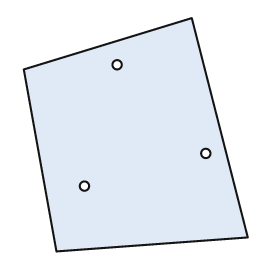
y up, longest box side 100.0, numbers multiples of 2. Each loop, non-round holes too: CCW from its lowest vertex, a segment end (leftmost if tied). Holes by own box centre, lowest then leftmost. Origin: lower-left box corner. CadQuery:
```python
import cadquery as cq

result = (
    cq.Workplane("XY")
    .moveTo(14.0, 0.0)
    .lineTo(96.0, 6.0)
    .lineTo(72.0, 100.0)
    .lineTo(0.0, 78.0)
    .close()
    .moveTo(26.0, 28.0)
    .circle(2.0)
    .moveTo(78.0, 42.0)
    .circle(2.0)
    .moveTo(40.0, 80.0)
    .circle(2.0)
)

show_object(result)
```